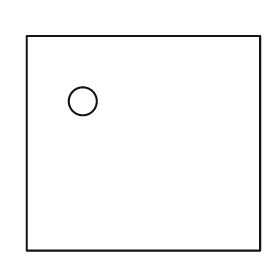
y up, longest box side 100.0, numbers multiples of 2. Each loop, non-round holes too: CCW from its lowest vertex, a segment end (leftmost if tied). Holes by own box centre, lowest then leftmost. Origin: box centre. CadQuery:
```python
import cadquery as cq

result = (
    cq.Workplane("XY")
    .moveTo(-50.0, -46.0)
    .lineTo(50.0, -46.0)
    .lineTo(50.0, 46.0)
    .lineTo(-50.0, 46.0)
    .close()
    .moveTo(-26.0, 18.0)
    .circle(6.0)
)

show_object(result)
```